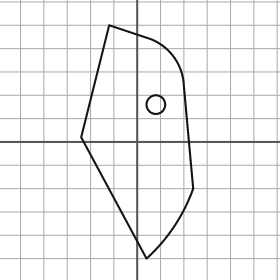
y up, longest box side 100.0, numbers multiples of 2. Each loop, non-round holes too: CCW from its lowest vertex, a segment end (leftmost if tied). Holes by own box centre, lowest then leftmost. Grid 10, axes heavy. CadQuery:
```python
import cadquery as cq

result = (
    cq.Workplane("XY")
    .moveTo(4.0, -50.0)
    .threePointArc((16.0, -36.0), (24.0, -20.0))
    .lineTo(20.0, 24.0)
    .threePointArc((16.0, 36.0), (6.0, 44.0))
    .lineTo(-12.0, 50.0)
    .lineTo(-24.0, 2.0)
    .close()
    .moveTo(8.0, 16.0)
    .circle(4.0)
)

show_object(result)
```